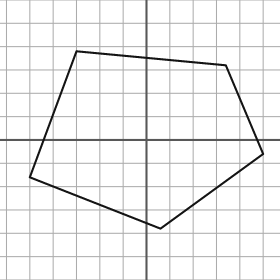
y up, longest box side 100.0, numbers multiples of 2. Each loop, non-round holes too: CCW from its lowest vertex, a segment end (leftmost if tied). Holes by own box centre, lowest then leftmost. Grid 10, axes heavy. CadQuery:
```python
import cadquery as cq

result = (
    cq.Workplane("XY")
    .moveTo(6.0, -38.0)
    .lineTo(50.0, -6.0)
    .lineTo(34.0, 32.0)
    .lineTo(-30.0, 38.0)
    .lineTo(-50.0, -16.0)
    .close()
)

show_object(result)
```